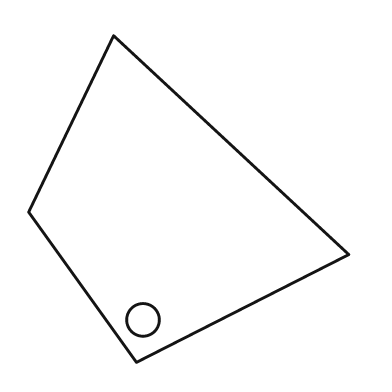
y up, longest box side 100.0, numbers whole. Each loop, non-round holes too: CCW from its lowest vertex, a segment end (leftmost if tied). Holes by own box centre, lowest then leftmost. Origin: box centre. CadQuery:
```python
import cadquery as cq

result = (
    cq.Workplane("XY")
    .moveTo(-16.0, -50.0)
    .lineTo(49.0, -17.0)
    .lineTo(-23.0, 50.0)
    .lineTo(-49.0, -4.0)
    .close()
    .moveTo(-14.0, -37.0)
    .circle(5.0)
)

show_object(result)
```